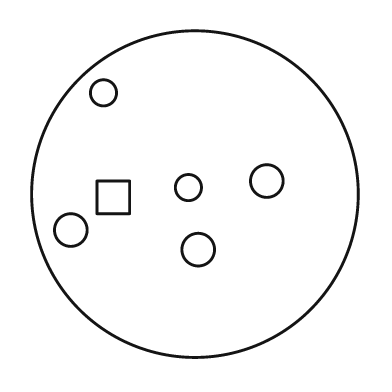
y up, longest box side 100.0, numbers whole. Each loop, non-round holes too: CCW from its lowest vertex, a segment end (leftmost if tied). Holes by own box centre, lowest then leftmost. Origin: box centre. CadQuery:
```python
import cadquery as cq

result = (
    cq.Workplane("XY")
    .moveTo(0.0, 0.0)
    .circle(50.0)
    .moveTo(1.0, -17.0)
    .circle(5.0)
    .moveTo(-38.0, -11.0)
    .circle(5.0)
    .moveTo(-30.0, -6.0)
    .lineTo(-20.0, -6.0)
    .lineTo(-20.0, 4.0)
    .lineTo(-30.0, 4.0)
    .close()
    .moveTo(-2.0, 2.0)
    .circle(4.0)
    .moveTo(22.0, 4.0)
    .circle(5.0)
    .moveTo(-28.0, 31.0)
    .circle(4.0)
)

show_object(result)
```